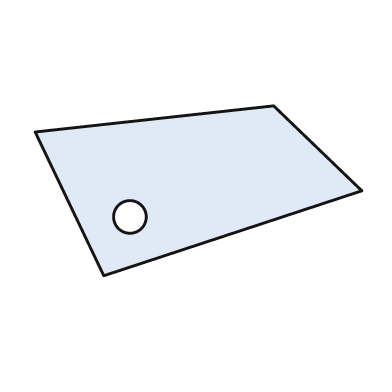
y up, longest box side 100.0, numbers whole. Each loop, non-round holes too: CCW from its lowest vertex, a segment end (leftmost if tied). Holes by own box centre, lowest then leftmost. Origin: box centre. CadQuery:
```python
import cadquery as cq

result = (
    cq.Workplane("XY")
    .moveTo(-29.0, -26.0)
    .lineTo(50.0, 0.0)
    .lineTo(23.0, 26.0)
    .lineTo(-50.0, 18.0)
    .close()
    .moveTo(-21.0, -8.0)
    .circle(5.0)
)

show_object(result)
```